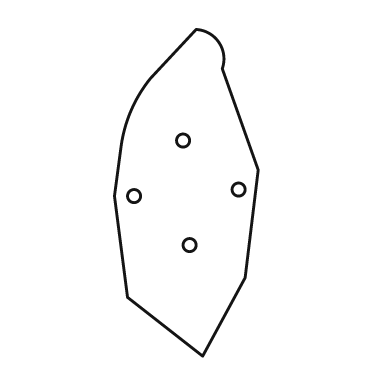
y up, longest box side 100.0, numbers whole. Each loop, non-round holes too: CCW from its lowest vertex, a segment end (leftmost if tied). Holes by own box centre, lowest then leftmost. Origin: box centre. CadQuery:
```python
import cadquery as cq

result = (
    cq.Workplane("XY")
    .moveTo(5.0, -50.0)
    .lineTo(18.0, -26.0)
    .lineTo(22.0, 7.0)
    .lineTo(11.0, 38.0)
    .threePointArc((10.0, 46.0), (3.0, 50.0))
    .lineTo(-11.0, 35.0)
    .threePointArc((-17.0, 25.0), (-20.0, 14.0))
    .lineTo(-22.0, -1.0)
    .lineTo(-18.0, -32.0)
    .close()
    .moveTo(1.0, -16.0)
    .circle(2.0)
    .moveTo(-16.0, -1.0)
    .circle(2.0)
    .moveTo(16.0, 1.0)
    .circle(2.0)
    .moveTo(-1.0, 16.0)
    .circle(2.0)
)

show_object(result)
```